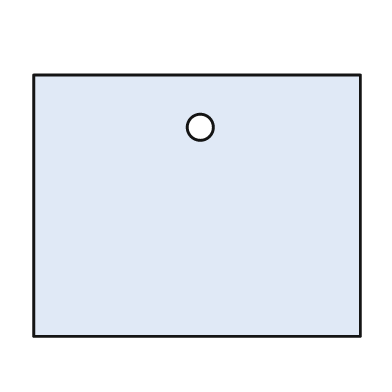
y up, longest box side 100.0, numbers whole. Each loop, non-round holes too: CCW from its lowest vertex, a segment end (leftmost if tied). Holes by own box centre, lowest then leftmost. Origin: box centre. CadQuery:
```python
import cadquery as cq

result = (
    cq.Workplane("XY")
    .moveTo(-50.0, -40.0)
    .lineTo(50.0, -40.0)
    .lineTo(50.0, 40.0)
    .lineTo(-50.0, 40.0)
    .close()
    .moveTo(1.0, 24.0)
    .circle(4.0)
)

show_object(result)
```